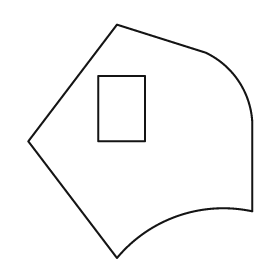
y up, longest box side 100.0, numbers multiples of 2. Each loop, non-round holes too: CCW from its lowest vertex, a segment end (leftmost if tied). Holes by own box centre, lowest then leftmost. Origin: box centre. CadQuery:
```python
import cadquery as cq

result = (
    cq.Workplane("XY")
    .moveTo(-10.0, -50.0)
    .threePointArc((16.0, -32.0), (48.0, -30.0))
    .lineTo(48.0, 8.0)
    .threePointArc((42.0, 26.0), (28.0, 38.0))
    .lineTo(-10.0, 50.0)
    .lineTo(-48.0, 0.0)
    .close()
    .moveTo(-18.0, 0.0)
    .lineTo(2.0, 0.0)
    .lineTo(2.0, 28.0)
    .lineTo(-18.0, 28.0)
    .close()
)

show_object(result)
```